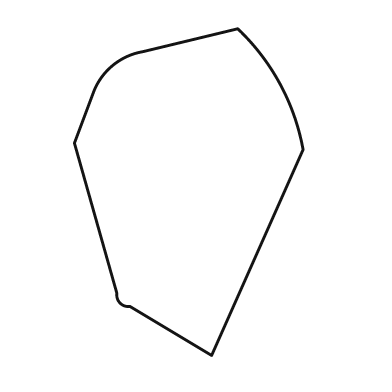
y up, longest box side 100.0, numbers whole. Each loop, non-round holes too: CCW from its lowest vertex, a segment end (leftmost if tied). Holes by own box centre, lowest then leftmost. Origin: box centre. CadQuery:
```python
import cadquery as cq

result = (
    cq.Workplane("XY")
    .moveTo(7.0, -50.0)
    .lineTo(35.0, 13.0)
    .threePointArc((28.0, 33.0), (15.0, 50.0))
    .lineTo(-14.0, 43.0)
    .threePointArc((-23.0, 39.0), (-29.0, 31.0))
    .lineTo(-35.0, 15.0)
    .lineTo(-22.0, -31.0)
    .threePointArc((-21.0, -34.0), (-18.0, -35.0))
    .close()
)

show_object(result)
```